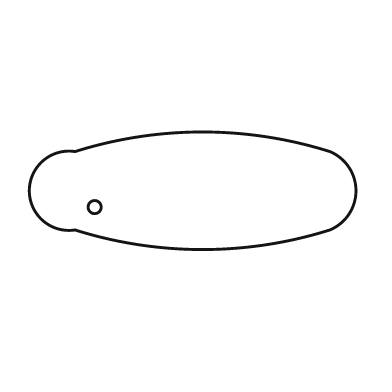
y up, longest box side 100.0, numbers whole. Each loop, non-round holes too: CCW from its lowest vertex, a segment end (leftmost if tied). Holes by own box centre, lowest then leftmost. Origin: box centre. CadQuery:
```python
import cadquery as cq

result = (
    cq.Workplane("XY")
    .moveTo(-36.0, -12.0)
    .threePointArc((3.0, -18.0), (42.0, -12.0))
    .threePointArc((50.0, 0.0), (42.0, 12.0))
    .threePointArc((3.0, 18.0), (-36.0, 12.0))
    .threePointArc((-50.0, 0.0), (-36.0, -12.0))
    .close()
    .moveTo(-30.0, -5.0)
    .circle(2.0)
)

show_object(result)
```